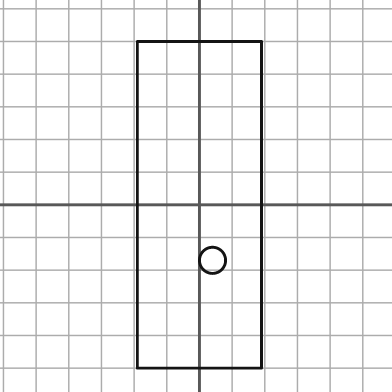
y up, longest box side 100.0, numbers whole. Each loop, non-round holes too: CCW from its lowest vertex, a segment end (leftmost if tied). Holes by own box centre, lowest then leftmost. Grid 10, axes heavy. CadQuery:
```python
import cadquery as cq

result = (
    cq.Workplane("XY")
    .moveTo(-19.0, -50.0)
    .lineTo(19.0, -50.0)
    .lineTo(19.0, 50.0)
    .lineTo(-19.0, 50.0)
    .close()
    .moveTo(4.0, -17.0)
    .circle(4.0)
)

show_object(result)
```